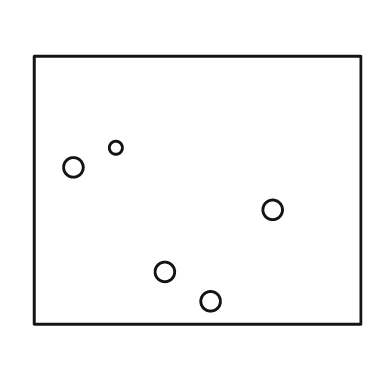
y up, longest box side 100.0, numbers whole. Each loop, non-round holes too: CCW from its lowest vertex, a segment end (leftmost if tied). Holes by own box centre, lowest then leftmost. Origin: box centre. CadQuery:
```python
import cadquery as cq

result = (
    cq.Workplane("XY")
    .moveTo(-50.0, -41.0)
    .lineTo(50.0, -41.0)
    .lineTo(50.0, 41.0)
    .lineTo(-50.0, 41.0)
    .close()
    .moveTo(4.0, -34.0)
    .circle(3.0)
    .moveTo(-10.0, -25.0)
    .circle(3.0)
    .moveTo(23.0, -6.0)
    .circle(3.0)
    .moveTo(-38.0, 7.0)
    .circle(3.0)
    .moveTo(-25.0, 13.0)
    .circle(2.0)
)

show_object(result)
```